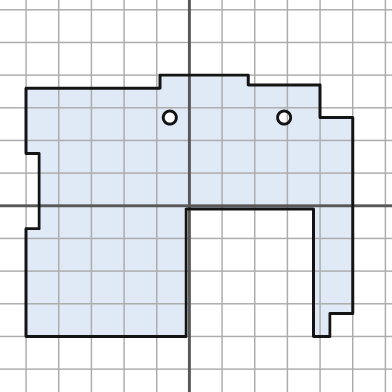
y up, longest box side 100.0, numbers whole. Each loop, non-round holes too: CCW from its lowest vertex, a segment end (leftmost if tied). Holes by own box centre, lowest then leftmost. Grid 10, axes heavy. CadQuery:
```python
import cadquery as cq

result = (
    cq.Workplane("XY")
    .moveTo(-50.0, -40.0)
    .lineTo(-1.0, -40.0)
    .lineTo(-1.0, -1.0)
    .lineTo(38.0, -1.0)
    .lineTo(38.0, -40.0)
    .lineTo(43.0, -40.0)
    .lineTo(43.0, -33.0)
    .lineTo(50.0, -33.0)
    .lineTo(50.0, 27.0)
    .lineTo(40.0, 27.0)
    .lineTo(40.0, 37.0)
    .lineTo(18.0, 37.0)
    .lineTo(18.0, 40.0)
    .lineTo(-9.0, 40.0)
    .lineTo(-9.0, 36.0)
    .lineTo(-50.0, 36.0)
    .lineTo(-50.0, 16.0)
    .lineTo(-46.0, 16.0)
    .lineTo(-46.0, -7.0)
    .lineTo(-50.0, -7.0)
    .close()
    .moveTo(-6.0, 27.0)
    .circle(2.0)
    .moveTo(29.0, 27.0)
    .circle(2.0)
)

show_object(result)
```